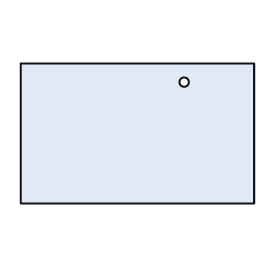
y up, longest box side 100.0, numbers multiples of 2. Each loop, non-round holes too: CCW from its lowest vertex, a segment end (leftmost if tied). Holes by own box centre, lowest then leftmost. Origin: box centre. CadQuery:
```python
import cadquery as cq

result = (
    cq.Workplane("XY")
    .moveTo(-50.0, -30.0)
    .lineTo(50.0, -30.0)
    .lineTo(50.0, 30.0)
    .lineTo(-50.0, 30.0)
    .close()
    .moveTo(20.0, 22.0)
    .circle(2.0)
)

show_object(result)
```